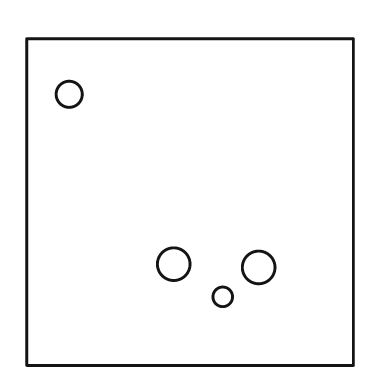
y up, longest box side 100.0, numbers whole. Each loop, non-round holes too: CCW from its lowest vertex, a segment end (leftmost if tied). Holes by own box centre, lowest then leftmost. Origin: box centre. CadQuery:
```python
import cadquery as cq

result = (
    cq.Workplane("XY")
    .moveTo(-50.0, -50.0)
    .lineTo(50.0, -50.0)
    .lineTo(50.0, 50.0)
    .lineTo(-50.0, 50.0)
    .close()
    .moveTo(10.0, -29.0)
    .circle(3.0)
    .moveTo(21.0, -20.0)
    .circle(5.0)
    .moveTo(-5.0, -19.0)
    .circle(5.0)
    .moveTo(-37.0, 33.0)
    .circle(4.0)
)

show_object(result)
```